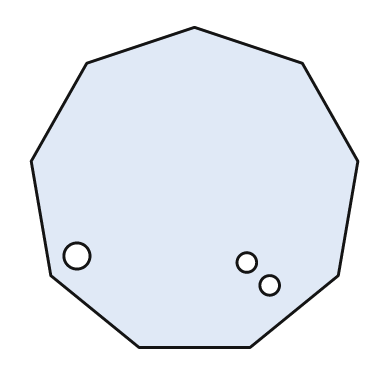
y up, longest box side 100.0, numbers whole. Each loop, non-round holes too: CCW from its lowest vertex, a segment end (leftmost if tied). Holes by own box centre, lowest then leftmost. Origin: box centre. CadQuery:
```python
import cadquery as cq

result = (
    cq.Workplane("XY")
    .moveTo(-17.0, -49.0)
    .lineTo(17.0, -49.0)
    .lineTo(44.0, -27.0)
    .lineTo(50.0, 8.0)
    .lineTo(33.0, 38.0)
    .lineTo(0.0, 49.0)
    .lineTo(-33.0, 38.0)
    .lineTo(-50.0, 8.0)
    .lineTo(-44.0, -27.0)
    .close()
    .moveTo(23.0, -30.0)
    .circle(3.0)
    .moveTo(16.0, -23.0)
    .circle(3.0)
    .moveTo(-36.0, -21.0)
    .circle(4.0)
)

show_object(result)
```